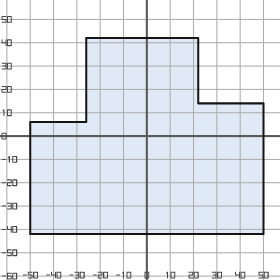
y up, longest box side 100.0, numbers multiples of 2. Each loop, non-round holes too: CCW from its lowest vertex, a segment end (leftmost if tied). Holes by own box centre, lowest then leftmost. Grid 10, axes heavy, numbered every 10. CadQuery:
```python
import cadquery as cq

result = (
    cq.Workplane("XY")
    .moveTo(-50.0, -42.0)
    .lineTo(50.0, -42.0)
    .lineTo(50.0, 14.0)
    .lineTo(22.0, 14.0)
    .lineTo(22.0, 42.0)
    .lineTo(-26.0, 42.0)
    .lineTo(-26.0, 6.0)
    .lineTo(-50.0, 6.0)
    .close()
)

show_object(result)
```